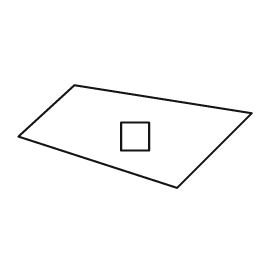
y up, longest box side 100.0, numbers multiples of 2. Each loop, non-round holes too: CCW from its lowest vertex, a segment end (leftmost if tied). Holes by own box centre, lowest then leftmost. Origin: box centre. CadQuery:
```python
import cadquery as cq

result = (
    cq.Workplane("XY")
    .moveTo(18.0, -22.0)
    .lineTo(50.0, 10.0)
    .lineTo(-26.0, 22.0)
    .lineTo(-50.0, 0.0)
    .close()
    .moveTo(-6.0, -6.0)
    .lineTo(6.0, -6.0)
    .lineTo(6.0, 6.0)
    .lineTo(-6.0, 6.0)
    .close()
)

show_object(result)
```